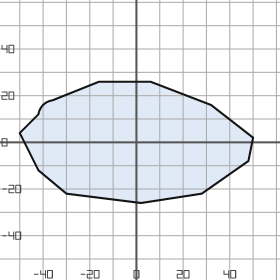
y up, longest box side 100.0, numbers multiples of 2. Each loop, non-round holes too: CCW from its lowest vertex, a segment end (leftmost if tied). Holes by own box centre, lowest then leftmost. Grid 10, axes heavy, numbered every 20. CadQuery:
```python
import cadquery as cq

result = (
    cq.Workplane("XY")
    .moveTo(2.0, -26.0)
    .lineTo(28.0, -22.0)
    .lineTo(48.0, -8.0)
    .lineTo(50.0, 2.0)
    .lineTo(32.0, 16.0)
    .lineTo(6.0, 26.0)
    .lineTo(-16.0, 26.0)
    .lineTo(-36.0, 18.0)
    .threePointArc((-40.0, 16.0), (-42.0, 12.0))
    .lineTo(-50.0, 4.0)
    .lineTo(-42.0, -12.0)
    .lineTo(-30.0, -22.0)
    .close()
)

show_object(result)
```